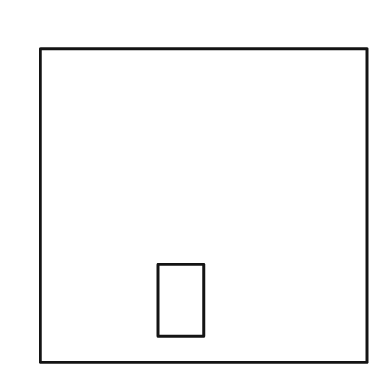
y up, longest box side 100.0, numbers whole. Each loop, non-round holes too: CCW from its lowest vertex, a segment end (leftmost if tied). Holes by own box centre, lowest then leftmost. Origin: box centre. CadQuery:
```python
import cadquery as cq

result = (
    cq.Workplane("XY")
    .moveTo(-50.0, -48.0)
    .lineTo(50.0, -48.0)
    .lineTo(50.0, 48.0)
    .lineTo(-50.0, 48.0)
    .close()
    .moveTo(-14.0, -40.0)
    .lineTo(0.0, -40.0)
    .lineTo(0.0, -18.0)
    .lineTo(-14.0, -18.0)
    .close()
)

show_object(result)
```